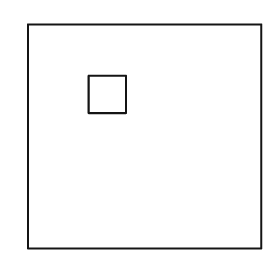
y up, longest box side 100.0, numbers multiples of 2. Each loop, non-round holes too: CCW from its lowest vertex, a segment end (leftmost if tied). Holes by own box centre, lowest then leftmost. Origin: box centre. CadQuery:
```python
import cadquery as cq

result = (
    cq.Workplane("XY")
    .moveTo(-50.0, -48.0)
    .lineTo(50.0, -48.0)
    .lineTo(50.0, 48.0)
    .lineTo(-50.0, 48.0)
    .close()
    .moveTo(-24.0, 10.0)
    .lineTo(-8.0, 10.0)
    .lineTo(-8.0, 26.0)
    .lineTo(-24.0, 26.0)
    .close()
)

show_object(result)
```